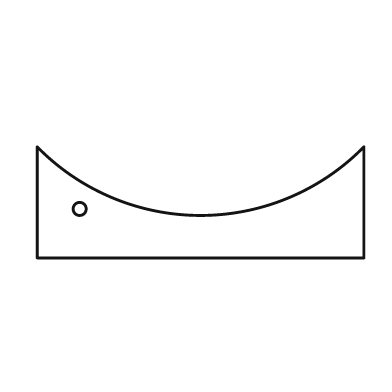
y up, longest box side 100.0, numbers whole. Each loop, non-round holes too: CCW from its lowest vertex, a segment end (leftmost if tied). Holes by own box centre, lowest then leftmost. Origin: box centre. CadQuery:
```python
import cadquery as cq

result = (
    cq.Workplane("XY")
    .moveTo(-50.0, -17.0)
    .lineTo(50.0, -17.0)
    .lineTo(50.0, 17.0)
    .threePointArc((0.0, -4.0), (-50.0, 17.0))
    .close()
    .moveTo(-37.0, -2.0)
    .circle(2.0)
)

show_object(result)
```